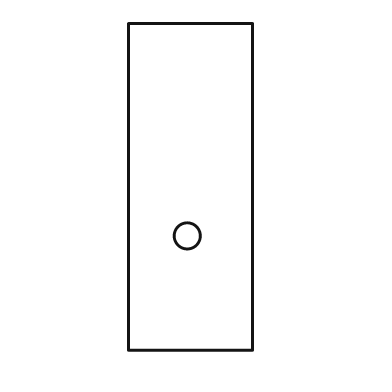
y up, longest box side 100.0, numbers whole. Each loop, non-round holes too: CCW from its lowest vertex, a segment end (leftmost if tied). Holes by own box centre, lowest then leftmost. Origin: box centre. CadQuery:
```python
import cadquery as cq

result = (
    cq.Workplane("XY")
    .moveTo(-19.0, -50.0)
    .lineTo(19.0, -50.0)
    .lineTo(19.0, 50.0)
    .lineTo(-19.0, 50.0)
    .close()
    .moveTo(-1.0, -15.0)
    .circle(4.0)
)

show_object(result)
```